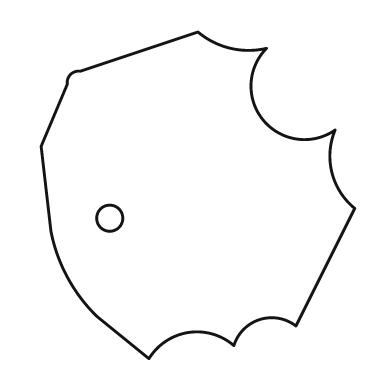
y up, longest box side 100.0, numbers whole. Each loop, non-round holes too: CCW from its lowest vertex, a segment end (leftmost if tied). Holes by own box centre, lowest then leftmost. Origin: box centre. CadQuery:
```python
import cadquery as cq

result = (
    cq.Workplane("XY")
    .moveTo(-15.0, -50.0)
    .threePointArc((-3.0, -42.0), (11.0, -46.0))
    .threePointArc((19.0, -38.0), (30.0, -40.0))
    .lineTo(48.0, -4.0)
    .threePointArc((41.0, 7.0), (42.0, 20.0))
    .threePointArc((20.0, 23.0), (21.0, 45.0))
    .threePointArc((10.0, 45.0), (0.0, 50.0))
    .lineTo(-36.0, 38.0)
    .threePointArc((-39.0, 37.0), (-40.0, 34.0))
    .lineTo(-48.0, 15.0)
    .lineTo(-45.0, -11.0)
    .threePointArc((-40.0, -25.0), (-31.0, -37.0))
    .close()
    .moveTo(-27.0, -7.0)
    .circle(4.0)
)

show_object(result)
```